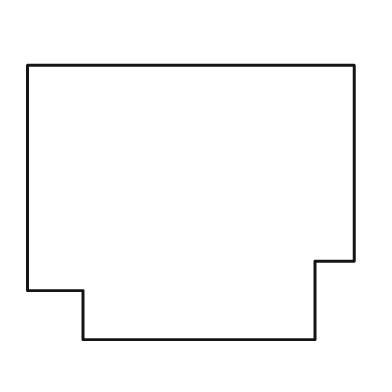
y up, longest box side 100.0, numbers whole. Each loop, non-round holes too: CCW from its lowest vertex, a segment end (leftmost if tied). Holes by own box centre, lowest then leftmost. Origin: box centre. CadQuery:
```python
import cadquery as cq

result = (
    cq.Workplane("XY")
    .moveTo(-33.0, -42.0)
    .lineTo(38.0, -42.0)
    .lineTo(38.0, -18.0)
    .lineTo(50.0, -18.0)
    .lineTo(50.0, 42.0)
    .lineTo(-50.0, 42.0)
    .lineTo(-50.0, -27.0)
    .lineTo(-33.0, -27.0)
    .close()
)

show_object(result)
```